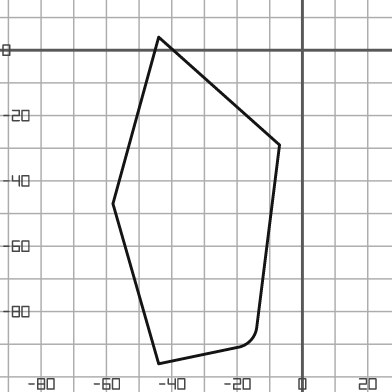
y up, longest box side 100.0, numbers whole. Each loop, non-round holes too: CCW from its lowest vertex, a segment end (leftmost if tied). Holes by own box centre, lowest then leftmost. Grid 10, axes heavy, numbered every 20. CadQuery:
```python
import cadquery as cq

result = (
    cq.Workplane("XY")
    .moveTo(-44.0, -96.0)
    .lineTo(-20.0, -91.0)
    .threePointArc((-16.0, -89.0), (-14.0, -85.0))
    .lineTo(-7.0, -29.0)
    .lineTo(-44.0, 4.0)
    .lineTo(-58.0, -47.0)
    .close()
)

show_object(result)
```